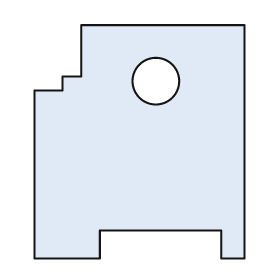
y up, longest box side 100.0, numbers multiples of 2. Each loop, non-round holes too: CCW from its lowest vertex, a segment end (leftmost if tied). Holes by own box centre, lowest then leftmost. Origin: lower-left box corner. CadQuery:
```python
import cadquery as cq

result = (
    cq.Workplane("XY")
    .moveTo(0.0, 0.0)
    .lineTo(28.0, 0.0)
    .lineTo(28.0, 12.0)
    .lineTo(80.0, 12.0)
    .lineTo(80.0, 0.0)
    .lineTo(90.0, 0.0)
    .lineTo(90.0, 100.0)
    .lineTo(20.0, 100.0)
    .lineTo(20.0, 78.0)
    .lineTo(12.0, 78.0)
    .lineTo(12.0, 72.0)
    .lineTo(0.0, 72.0)
    .close()
    .moveTo(52.0, 76.0)
    .circle(10.0)
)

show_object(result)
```